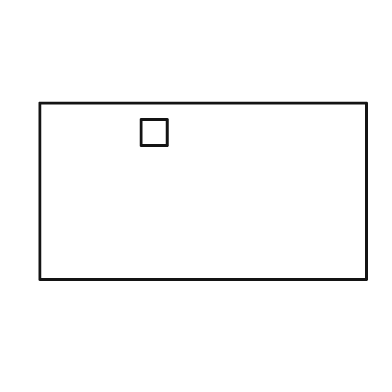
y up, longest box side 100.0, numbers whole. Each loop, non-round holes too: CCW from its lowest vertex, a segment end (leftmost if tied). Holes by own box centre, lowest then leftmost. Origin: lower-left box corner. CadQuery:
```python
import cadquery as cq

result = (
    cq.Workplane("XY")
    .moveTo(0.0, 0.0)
    .lineTo(100.0, 0.0)
    .lineTo(100.0, 54.0)
    .lineTo(0.0, 54.0)
    .close()
    .moveTo(31.0, 41.0)
    .lineTo(39.0, 41.0)
    .lineTo(39.0, 49.0)
    .lineTo(31.0, 49.0)
    .close()
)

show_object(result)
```